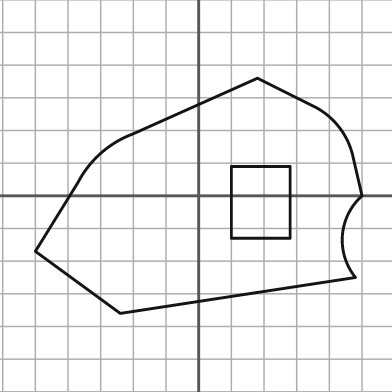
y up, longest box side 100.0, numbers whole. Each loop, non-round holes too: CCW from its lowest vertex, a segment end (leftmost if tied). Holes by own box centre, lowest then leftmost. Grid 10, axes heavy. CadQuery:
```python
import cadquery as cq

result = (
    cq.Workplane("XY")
    .moveTo(-24.0, -36.0)
    .lineTo(48.0, -25.0)
    .threePointArc((44.0, -12.0), (50.0, 0.0))
    .lineTo(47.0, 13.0)
    .threePointArc((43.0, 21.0), (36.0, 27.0))
    .lineTo(18.0, 36.0)
    .lineTo(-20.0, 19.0)
    .threePointArc((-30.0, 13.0), (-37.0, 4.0))
    .lineTo(-50.0, -17.0)
    .close()
    .moveTo(10.0, -13.0)
    .lineTo(28.0, -13.0)
    .lineTo(28.0, 9.0)
    .lineTo(10.0, 9.0)
    .close()
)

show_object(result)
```